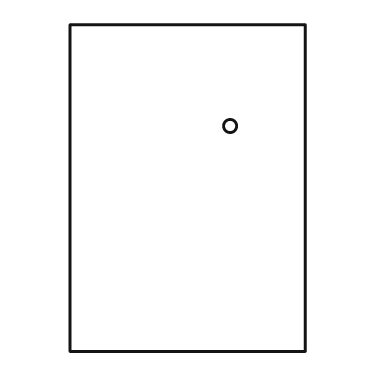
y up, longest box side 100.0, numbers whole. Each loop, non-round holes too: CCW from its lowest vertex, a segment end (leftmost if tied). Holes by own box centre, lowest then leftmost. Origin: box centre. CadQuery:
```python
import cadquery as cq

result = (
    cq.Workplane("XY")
    .moveTo(-36.0, -50.0)
    .lineTo(36.0, -50.0)
    .lineTo(36.0, 50.0)
    .lineTo(-36.0, 50.0)
    .close()
    .moveTo(13.0, 19.0)
    .circle(2.0)
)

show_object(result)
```